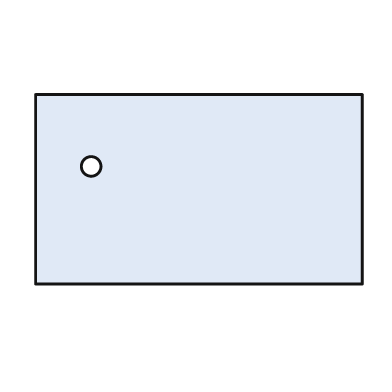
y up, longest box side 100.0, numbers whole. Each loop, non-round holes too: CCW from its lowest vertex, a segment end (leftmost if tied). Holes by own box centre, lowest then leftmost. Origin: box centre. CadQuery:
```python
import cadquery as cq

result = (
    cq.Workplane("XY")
    .moveTo(-50.0, -29.0)
    .lineTo(50.0, -29.0)
    .lineTo(50.0, 29.0)
    .lineTo(-50.0, 29.0)
    .close()
    .moveTo(-33.0, 7.0)
    .circle(3.0)
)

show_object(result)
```